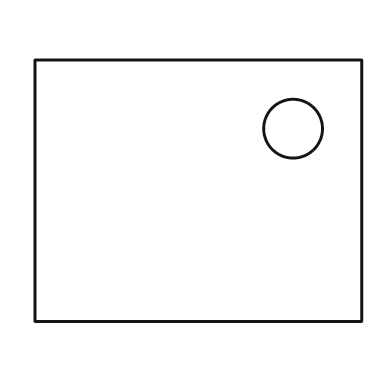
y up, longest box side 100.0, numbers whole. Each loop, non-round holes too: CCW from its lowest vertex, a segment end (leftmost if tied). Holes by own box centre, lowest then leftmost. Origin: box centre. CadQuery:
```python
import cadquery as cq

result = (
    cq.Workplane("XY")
    .moveTo(-50.0, -40.0)
    .lineTo(50.0, -40.0)
    .lineTo(50.0, 40.0)
    .lineTo(-50.0, 40.0)
    .close()
    .moveTo(29.0, 19.0)
    .circle(9.0)
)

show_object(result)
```